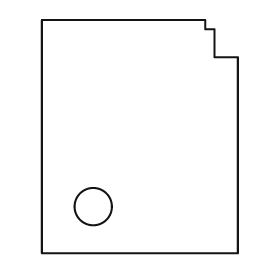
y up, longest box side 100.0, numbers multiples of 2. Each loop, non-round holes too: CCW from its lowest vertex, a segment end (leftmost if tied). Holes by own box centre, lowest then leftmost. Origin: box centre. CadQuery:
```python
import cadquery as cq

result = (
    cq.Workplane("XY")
    .moveTo(-42.0, -50.0)
    .lineTo(42.0, -50.0)
    .lineTo(42.0, 34.0)
    .lineTo(32.0, 34.0)
    .lineTo(32.0, 46.0)
    .lineTo(28.0, 46.0)
    .lineTo(28.0, 50.0)
    .lineTo(-42.0, 50.0)
    .close()
    .moveTo(-20.0, -30.0)
    .circle(8.0)
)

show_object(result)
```